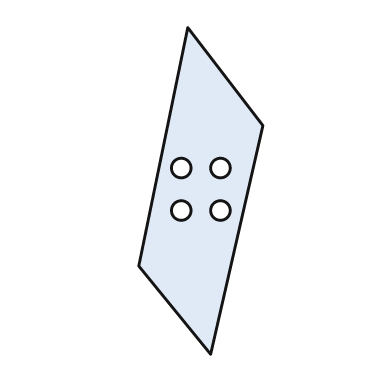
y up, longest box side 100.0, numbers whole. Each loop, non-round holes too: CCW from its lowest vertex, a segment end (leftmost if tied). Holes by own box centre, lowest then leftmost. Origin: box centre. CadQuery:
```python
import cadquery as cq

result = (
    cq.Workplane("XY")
    .moveTo(3.0, -50.0)
    .lineTo(19.0, 20.0)
    .lineTo(-4.0, 50.0)
    .lineTo(-19.0, -23.0)
    .close()
    .moveTo(-6.0, -6.0)
    .circle(3.0)
    .moveTo(6.0, -6.0)
    .circle(3.0)
    .moveTo(-6.0, 7.0)
    .circle(3.0)
    .moveTo(6.0, 7.0)
    .circle(3.0)
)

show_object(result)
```